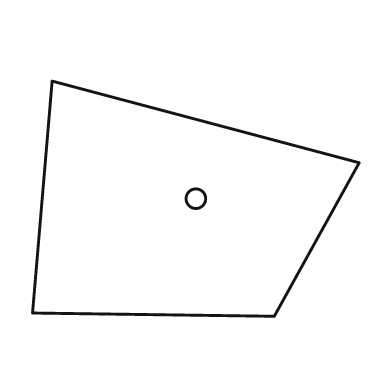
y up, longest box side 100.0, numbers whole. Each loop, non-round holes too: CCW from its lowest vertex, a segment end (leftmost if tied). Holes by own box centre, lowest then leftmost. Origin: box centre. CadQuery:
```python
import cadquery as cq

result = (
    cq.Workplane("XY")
    .moveTo(24.0, -36.0)
    .lineTo(50.0, 11.0)
    .lineTo(-44.0, 36.0)
    .lineTo(-50.0, -35.0)
    .close()
    .moveTo(0.0, 0.0)
    .circle(3.0)
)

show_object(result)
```